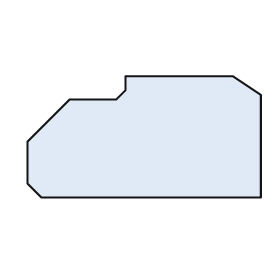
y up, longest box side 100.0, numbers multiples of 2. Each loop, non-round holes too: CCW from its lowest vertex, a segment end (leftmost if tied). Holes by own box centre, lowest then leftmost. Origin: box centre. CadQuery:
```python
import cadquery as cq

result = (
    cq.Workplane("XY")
    .moveTo(-44.0, -26.0)
    .lineTo(50.0, -26.0)
    .lineTo(50.0, 18.0)
    .lineTo(38.0, 26.0)
    .lineTo(-8.0, 26.0)
    .lineTo(-8.0, 20.0)
    .lineTo(-12.0, 16.0)
    .lineTo(-32.0, 16.0)
    .lineTo(-50.0, -2.0)
    .lineTo(-50.0, -20.0)
    .close()
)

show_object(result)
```